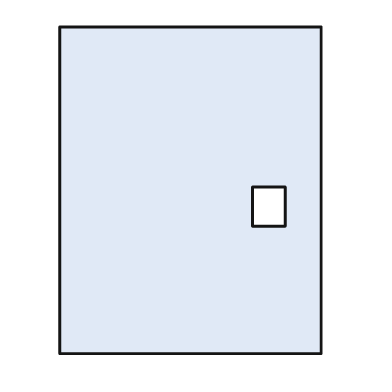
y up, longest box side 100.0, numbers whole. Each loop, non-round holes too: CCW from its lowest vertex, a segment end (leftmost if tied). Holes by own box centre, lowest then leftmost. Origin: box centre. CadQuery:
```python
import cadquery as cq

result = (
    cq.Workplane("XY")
    .moveTo(-40.0, -50.0)
    .lineTo(40.0, -50.0)
    .lineTo(40.0, 50.0)
    .lineTo(-40.0, 50.0)
    .close()
    .moveTo(19.0, -11.0)
    .lineTo(29.0, -11.0)
    .lineTo(29.0, 1.0)
    .lineTo(19.0, 1.0)
    .close()
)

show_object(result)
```